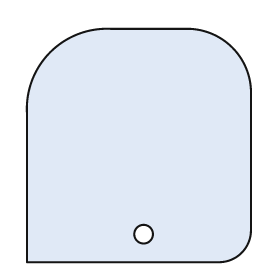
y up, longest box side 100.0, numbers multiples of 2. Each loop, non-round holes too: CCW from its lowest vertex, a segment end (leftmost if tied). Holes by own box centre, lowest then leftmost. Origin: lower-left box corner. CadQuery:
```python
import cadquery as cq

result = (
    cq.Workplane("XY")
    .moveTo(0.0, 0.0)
    .lineTo(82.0, 0.0)
    .threePointArc((92.0, 4.0), (96.0, 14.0))
    .lineTo(96.0, 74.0)
    .threePointArc((88.0, 92.0), (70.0, 100.0))
    .lineTo(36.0, 100.0)
    .threePointArc((10.0, 90.0), (0.0, 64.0))
    .close()
    .moveTo(50.0, 12.0)
    .circle(4.0)
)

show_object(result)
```